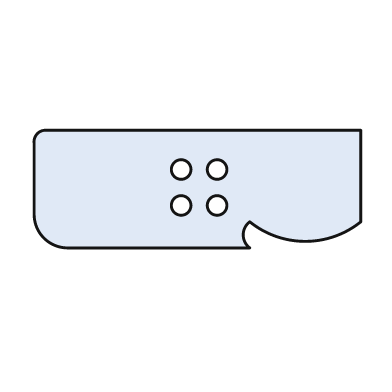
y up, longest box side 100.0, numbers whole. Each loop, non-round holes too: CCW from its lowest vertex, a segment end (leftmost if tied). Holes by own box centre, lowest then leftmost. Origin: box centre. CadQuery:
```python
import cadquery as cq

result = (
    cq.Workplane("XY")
    .moveTo(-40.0, -18.0)
    .lineTo(16.0, -18.0)
    .threePointArc((14.0, -14.0), (16.0, -10.0))
    .threePointArc((33.0, -16.0), (50.0, -10.0))
    .lineTo(50.0, 18.0)
    .lineTo(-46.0, 18.0)
    .threePointArc((-49.0, 17.0), (-50.0, 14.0))
    .lineTo(-50.0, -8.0)
    .threePointArc((-47.0, -15.0), (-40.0, -18.0))
    .close()
    .moveTo(-5.0, -5.0)
    .circle(3.0)
    .moveTo(6.0, -5.0)
    .circle(3.0)
    .moveTo(-5.0, 6.0)
    .circle(3.0)
    .moveTo(6.0, 6.0)
    .circle(3.0)
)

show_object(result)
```